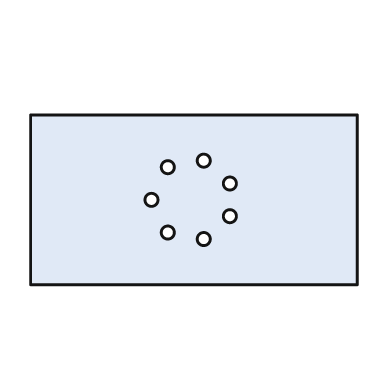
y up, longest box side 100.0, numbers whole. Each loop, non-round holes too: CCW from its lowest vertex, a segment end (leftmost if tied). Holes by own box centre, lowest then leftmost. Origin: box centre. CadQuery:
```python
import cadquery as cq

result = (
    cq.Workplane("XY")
    .moveTo(-50.0, -26.0)
    .lineTo(50.0, -26.0)
    .lineTo(50.0, 26.0)
    .lineTo(-50.0, 26.0)
    .close()
    .moveTo(3.0, -12.0)
    .circle(2.0)
    .moveTo(-8.0, -10.0)
    .circle(2.0)
    .moveTo(11.0, -5.0)
    .circle(2.0)
    .moveTo(-13.0, 0.0)
    .circle(2.0)
    .moveTo(11.0, 5.0)
    .circle(2.0)
    .moveTo(-8.0, 10.0)
    .circle(2.0)
    .moveTo(3.0, 12.0)
    .circle(2.0)
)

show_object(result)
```